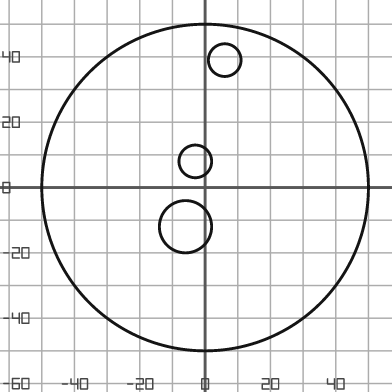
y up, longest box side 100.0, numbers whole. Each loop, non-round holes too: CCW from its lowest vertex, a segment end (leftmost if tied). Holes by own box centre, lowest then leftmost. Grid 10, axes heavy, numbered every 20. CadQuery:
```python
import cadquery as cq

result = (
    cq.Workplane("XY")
    .moveTo(0.0, 0.0)
    .circle(50.0)
    .moveTo(-6.0, -12.0)
    .circle(8.0)
    .moveTo(-3.0, 8.0)
    .circle(5.0)
    .moveTo(6.0, 39.0)
    .circle(5.0)
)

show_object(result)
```